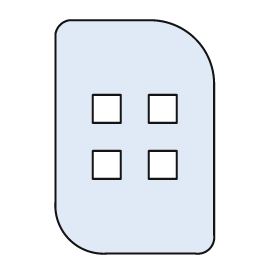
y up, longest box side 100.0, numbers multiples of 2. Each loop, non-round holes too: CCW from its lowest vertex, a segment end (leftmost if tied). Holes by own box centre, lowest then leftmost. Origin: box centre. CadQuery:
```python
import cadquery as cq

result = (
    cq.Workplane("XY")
    .moveTo(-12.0, -50.0)
    .lineTo(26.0, -50.0)
    .threePointArc((32.0, -48.0), (34.0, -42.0))
    .lineTo(34.0, 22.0)
    .threePointArc((26.0, 42.0), (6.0, 50.0))
    .lineTo(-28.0, 50.0)
    .threePointArc((-32.0, 48.0), (-34.0, 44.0))
    .lineTo(-34.0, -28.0)
    .threePointArc((-28.0, -44.0), (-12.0, -50.0))
    .close()
    .moveTo(-18.0, -18.0)
    .lineTo(-6.0, -18.0)
    .lineTo(-6.0, -6.0)
    .lineTo(-18.0, -6.0)
    .close()
    .moveTo(6.0, -18.0)
    .lineTo(18.0, -18.0)
    .lineTo(18.0, -6.0)
    .lineTo(6.0, -6.0)
    .close()
    .moveTo(-18.0, 6.0)
    .lineTo(-6.0, 6.0)
    .lineTo(-6.0, 18.0)
    .lineTo(-18.0, 18.0)
    .close()
    .moveTo(6.0, 6.0)
    .lineTo(18.0, 6.0)
    .lineTo(18.0, 18.0)
    .lineTo(6.0, 18.0)
    .close()
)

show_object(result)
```